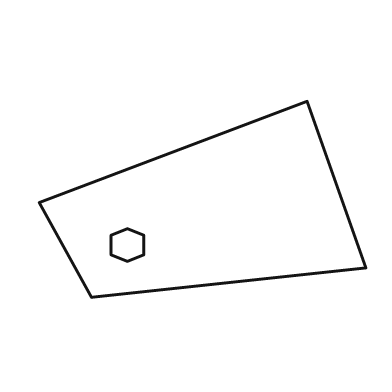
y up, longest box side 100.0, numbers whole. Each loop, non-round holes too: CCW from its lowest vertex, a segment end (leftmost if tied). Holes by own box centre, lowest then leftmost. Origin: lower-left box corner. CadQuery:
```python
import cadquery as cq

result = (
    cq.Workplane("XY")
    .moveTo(16.0, 0.0)
    .lineTo(100.0, 9.0)
    .lineTo(82.0, 60.0)
    .lineTo(0.0, 29.0)
    .close()
    .moveTo(27.0, 11.0)
    .lineTo(32.0, 13.0)
    .lineTo(32.0, 19.0)
    .lineTo(27.0, 21.0)
    .lineTo(22.0, 19.0)
    .lineTo(22.0, 13.0)
    .close()
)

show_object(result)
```